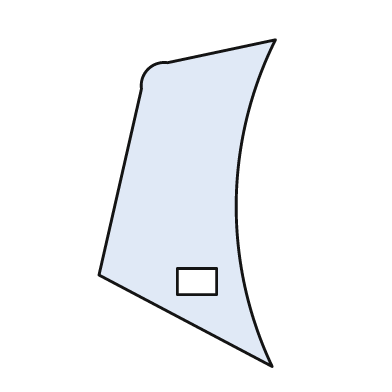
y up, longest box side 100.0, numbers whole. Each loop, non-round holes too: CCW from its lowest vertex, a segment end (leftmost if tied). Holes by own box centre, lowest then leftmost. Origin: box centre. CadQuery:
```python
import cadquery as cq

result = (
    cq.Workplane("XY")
    .moveTo(26.0, -50.0)
    .threePointArc((15.0, 0.0), (27.0, 50.0))
    .lineTo(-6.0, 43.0)
    .threePointArc((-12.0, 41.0), (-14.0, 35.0))
    .lineTo(-27.0, -22.0)
    .close()
    .moveTo(-3.0, -28.0)
    .lineTo(9.0, -28.0)
    .lineTo(9.0, -20.0)
    .lineTo(-3.0, -20.0)
    .close()
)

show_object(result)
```